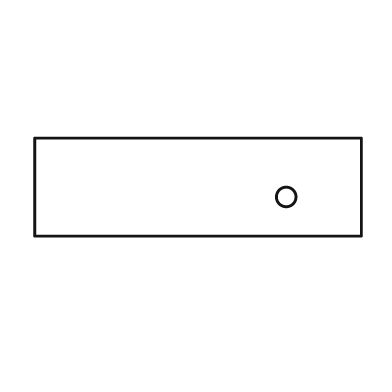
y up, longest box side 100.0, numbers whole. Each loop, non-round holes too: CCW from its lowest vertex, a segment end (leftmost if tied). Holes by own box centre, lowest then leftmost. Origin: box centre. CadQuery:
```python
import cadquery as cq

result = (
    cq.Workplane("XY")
    .moveTo(-50.0, -15.0)
    .lineTo(50.0, -15.0)
    .lineTo(50.0, 15.0)
    .lineTo(-50.0, 15.0)
    .close()
    .moveTo(27.0, -3.0)
    .circle(3.0)
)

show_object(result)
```